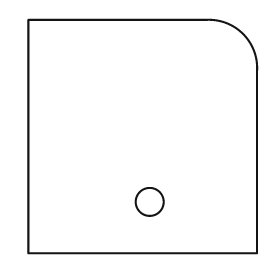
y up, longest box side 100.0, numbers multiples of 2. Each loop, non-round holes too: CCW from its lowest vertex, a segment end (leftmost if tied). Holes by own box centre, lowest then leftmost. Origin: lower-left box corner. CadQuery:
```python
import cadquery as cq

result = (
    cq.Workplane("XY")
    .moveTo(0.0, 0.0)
    .lineTo(98.0, 0.0)
    .lineTo(98.0, 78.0)
    .threePointArc((92.0, 94.0), (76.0, 100.0))
    .lineTo(0.0, 100.0)
    .close()
    .moveTo(52.0, 22.0)
    .circle(6.0)
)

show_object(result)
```